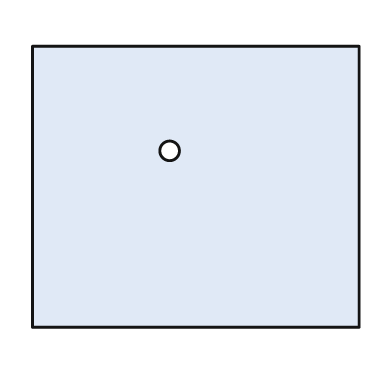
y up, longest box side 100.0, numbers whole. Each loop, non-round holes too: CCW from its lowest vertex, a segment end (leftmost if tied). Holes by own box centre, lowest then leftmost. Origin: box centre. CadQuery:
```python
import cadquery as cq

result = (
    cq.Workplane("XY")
    .moveTo(-50.0, -43.0)
    .lineTo(50.0, -43.0)
    .lineTo(50.0, 43.0)
    .lineTo(-50.0, 43.0)
    .close()
    .moveTo(-8.0, 11.0)
    .circle(3.0)
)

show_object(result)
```